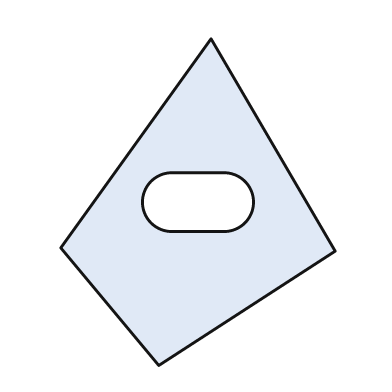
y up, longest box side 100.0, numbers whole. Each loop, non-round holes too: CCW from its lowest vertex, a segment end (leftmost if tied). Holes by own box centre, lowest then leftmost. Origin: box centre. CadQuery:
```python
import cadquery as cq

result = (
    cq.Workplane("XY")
    .moveTo(-12.0, -50.0)
    .lineTo(42.0, -15.0)
    .lineTo(4.0, 50.0)
    .lineTo(-42.0, -14.0)
    .close()
    .moveTo(-8.0, -9.0)
    .lineTo(8.0, -9.0)
    .threePointArc((17.0, 0.0), (8.0, 9.0))
    .lineTo(-8.0, 9.0)
    .threePointArc((-17.0, 0.0), (-8.0, -9.0))
    .close()
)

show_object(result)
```